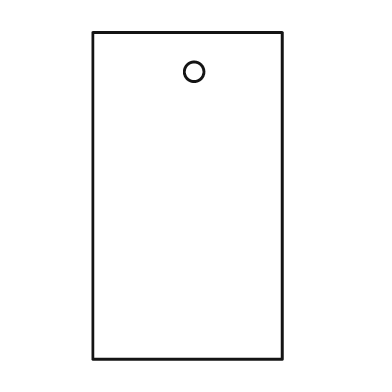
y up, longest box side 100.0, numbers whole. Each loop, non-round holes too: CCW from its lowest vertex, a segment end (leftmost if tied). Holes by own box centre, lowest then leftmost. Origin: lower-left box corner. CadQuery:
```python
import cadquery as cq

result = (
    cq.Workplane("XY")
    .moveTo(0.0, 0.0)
    .lineTo(58.0, 0.0)
    .lineTo(58.0, 100.0)
    .lineTo(0.0, 100.0)
    .close()
    .moveTo(31.0, 88.0)
    .circle(3.0)
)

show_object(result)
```